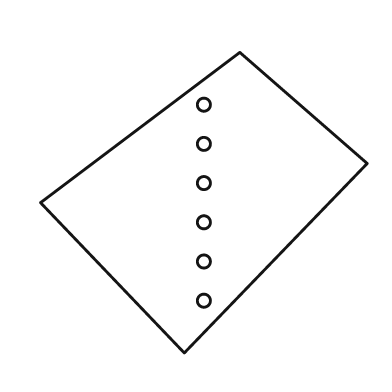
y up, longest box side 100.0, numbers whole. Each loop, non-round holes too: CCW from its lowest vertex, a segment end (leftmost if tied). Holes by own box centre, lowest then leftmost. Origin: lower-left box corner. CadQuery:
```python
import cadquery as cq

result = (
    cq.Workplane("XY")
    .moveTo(44.0, 0.0)
    .lineTo(100.0, 58.0)
    .lineTo(61.0, 92.0)
    .lineTo(0.0, 46.0)
    .close()
    .moveTo(50.0, 16.0)
    .circle(2.0)
    .moveTo(50.0, 28.0)
    .circle(2.0)
    .moveTo(50.0, 40.0)
    .circle(2.0)
    .moveTo(50.0, 52.0)
    .circle(2.0)
    .moveTo(50.0, 64.0)
    .circle(2.0)
    .moveTo(50.0, 76.0)
    .circle(2.0)
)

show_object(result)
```